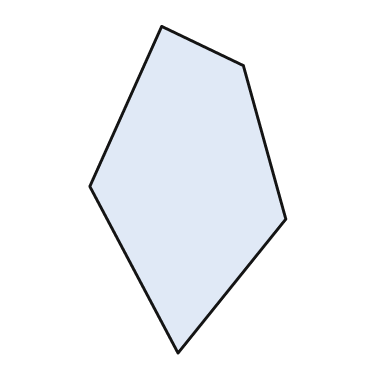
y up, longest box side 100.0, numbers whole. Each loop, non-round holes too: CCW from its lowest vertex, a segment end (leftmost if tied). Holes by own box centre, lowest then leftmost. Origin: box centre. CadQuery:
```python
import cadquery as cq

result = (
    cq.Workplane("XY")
    .moveTo(-3.0, -50.0)
    .lineTo(30.0, -9.0)
    .lineTo(17.0, 38.0)
    .lineTo(-8.0, 50.0)
    .lineTo(-30.0, 1.0)
    .close()
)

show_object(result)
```